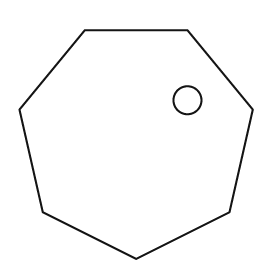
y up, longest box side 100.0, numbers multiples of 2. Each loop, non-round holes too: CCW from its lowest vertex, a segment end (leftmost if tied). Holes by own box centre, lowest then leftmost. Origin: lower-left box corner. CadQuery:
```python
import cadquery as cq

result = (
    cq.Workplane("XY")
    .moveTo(50.0, 0.0)
    .lineTo(90.0, 20.0)
    .lineTo(100.0, 64.0)
    .lineTo(72.0, 98.0)
    .lineTo(28.0, 98.0)
    .lineTo(0.0, 64.0)
    .lineTo(10.0, 20.0)
    .close()
    .moveTo(72.0, 68.0)
    .circle(6.0)
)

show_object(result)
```